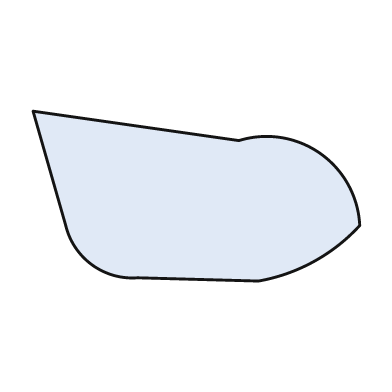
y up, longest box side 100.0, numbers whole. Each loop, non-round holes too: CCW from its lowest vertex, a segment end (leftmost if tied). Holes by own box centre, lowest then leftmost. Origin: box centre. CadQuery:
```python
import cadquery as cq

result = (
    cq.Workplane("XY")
    .moveTo(19.0, -26.0)
    .threePointArc((36.0, -20.0), (50.0, -9.0))
    .threePointArc((38.0, 13.0), (13.0, 17.0))
    .lineTo(-50.0, 26.0)
    .lineTo(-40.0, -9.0)
    .threePointArc((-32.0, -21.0), (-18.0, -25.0))
    .close()
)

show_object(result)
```